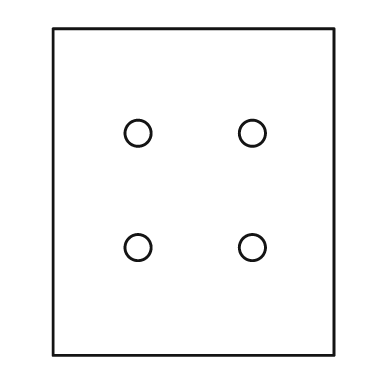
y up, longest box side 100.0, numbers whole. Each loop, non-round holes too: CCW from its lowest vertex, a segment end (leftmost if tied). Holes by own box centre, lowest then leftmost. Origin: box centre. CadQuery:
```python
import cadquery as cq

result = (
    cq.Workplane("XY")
    .moveTo(-43.0, -50.0)
    .lineTo(43.0, -50.0)
    .lineTo(43.0, 50.0)
    .lineTo(-43.0, 50.0)
    .close()
    .moveTo(-17.0, -17.0)
    .circle(4.0)
    .moveTo(18.0, -17.0)
    .circle(4.0)
    .moveTo(-17.0, 18.0)
    .circle(4.0)
    .moveTo(18.0, 18.0)
    .circle(4.0)
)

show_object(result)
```